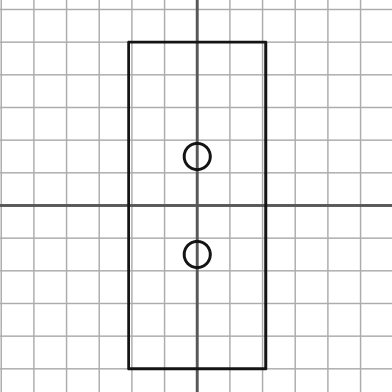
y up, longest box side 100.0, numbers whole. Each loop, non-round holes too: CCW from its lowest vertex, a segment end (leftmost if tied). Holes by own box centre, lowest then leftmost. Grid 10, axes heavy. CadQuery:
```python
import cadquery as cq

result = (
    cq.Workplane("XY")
    .moveTo(-21.0, -50.0)
    .lineTo(21.0, -50.0)
    .lineTo(21.0, 50.0)
    .lineTo(-21.0, 50.0)
    .close()
    .moveTo(0.0, -15.0)
    .circle(4.0)
    .moveTo(0.0, 15.0)
    .circle(4.0)
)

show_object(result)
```